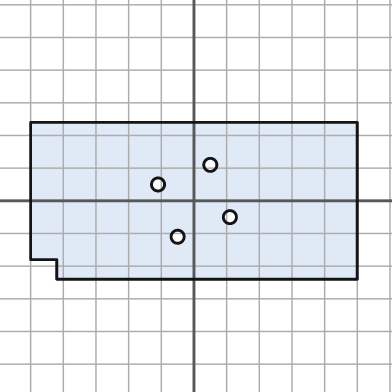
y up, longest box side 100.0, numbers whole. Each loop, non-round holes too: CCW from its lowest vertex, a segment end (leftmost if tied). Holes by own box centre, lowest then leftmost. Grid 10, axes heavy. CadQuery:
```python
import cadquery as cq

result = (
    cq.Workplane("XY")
    .moveTo(-42.0, -24.0)
    .lineTo(50.0, -24.0)
    .lineTo(50.0, 24.0)
    .lineTo(-50.0, 24.0)
    .lineTo(-50.0, -18.0)
    .lineTo(-42.0, -18.0)
    .close()
    .moveTo(-5.0, -11.0)
    .circle(2.0)
    .moveTo(11.0, -5.0)
    .circle(2.0)
    .moveTo(-11.0, 5.0)
    .circle(2.0)
    .moveTo(5.0, 11.0)
    .circle(2.0)
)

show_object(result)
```